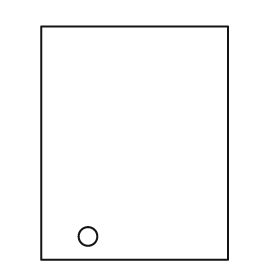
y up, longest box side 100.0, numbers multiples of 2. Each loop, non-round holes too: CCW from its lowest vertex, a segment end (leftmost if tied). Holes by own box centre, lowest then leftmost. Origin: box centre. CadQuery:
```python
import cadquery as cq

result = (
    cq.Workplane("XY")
    .moveTo(-40.0, -50.0)
    .lineTo(40.0, -50.0)
    .lineTo(40.0, 50.0)
    .lineTo(-40.0, 50.0)
    .close()
    .moveTo(-20.0, -40.0)
    .circle(4.0)
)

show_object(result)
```